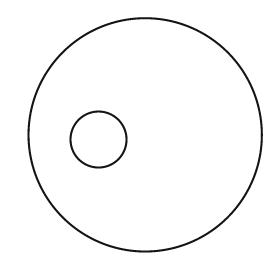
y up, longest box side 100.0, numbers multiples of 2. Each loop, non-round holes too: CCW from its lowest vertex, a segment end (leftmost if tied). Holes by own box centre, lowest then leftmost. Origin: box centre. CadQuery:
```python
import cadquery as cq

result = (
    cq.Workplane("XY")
    .moveTo(0.0, 0.0)
    .circle(50.0)
    .moveTo(-20.0, -2.0)
    .circle(12.0)
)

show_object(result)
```